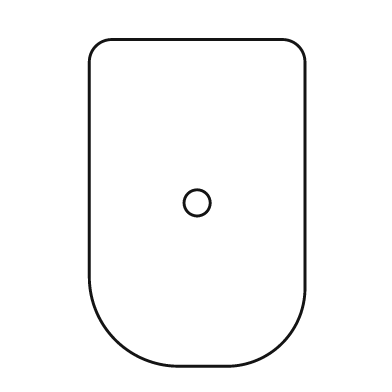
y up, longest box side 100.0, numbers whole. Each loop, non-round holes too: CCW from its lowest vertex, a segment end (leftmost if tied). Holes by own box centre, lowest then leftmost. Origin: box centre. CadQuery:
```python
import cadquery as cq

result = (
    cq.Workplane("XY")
    .moveTo(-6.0, -50.0)
    .lineTo(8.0, -50.0)
    .threePointArc((26.0, -43.0), (33.0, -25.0))
    .lineTo(33.0, 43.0)
    .threePointArc((31.0, 48.0), (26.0, 50.0))
    .lineTo(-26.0, 50.0)
    .threePointArc((-31.0, 48.0), (-33.0, 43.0))
    .lineTo(-33.0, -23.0)
    .threePointArc((-25.0, -42.0), (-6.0, -50.0))
    .close()
    .moveTo(0.0, 0.0)
    .circle(4.0)
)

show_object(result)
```